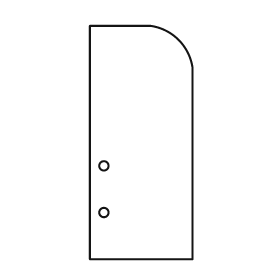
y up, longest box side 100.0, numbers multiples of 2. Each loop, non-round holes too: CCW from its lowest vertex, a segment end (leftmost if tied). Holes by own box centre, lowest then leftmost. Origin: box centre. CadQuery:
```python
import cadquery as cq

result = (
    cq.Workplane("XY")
    .moveTo(-22.0, -50.0)
    .lineTo(22.0, -50.0)
    .lineTo(22.0, 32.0)
    .threePointArc((16.0, 44.0), (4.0, 50.0))
    .lineTo(-22.0, 50.0)
    .close()
    .moveTo(-16.0, -30.0)
    .circle(2.0)
    .moveTo(-16.0, -10.0)
    .circle(2.0)
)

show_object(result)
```